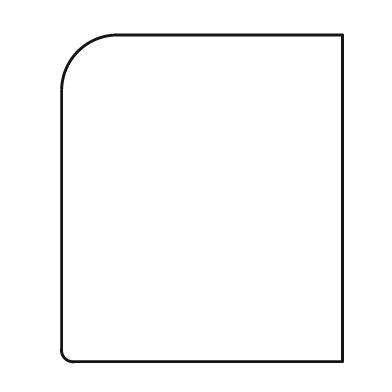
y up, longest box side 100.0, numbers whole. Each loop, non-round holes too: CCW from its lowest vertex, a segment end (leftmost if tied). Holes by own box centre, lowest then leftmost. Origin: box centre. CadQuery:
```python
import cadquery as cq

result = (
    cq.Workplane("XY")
    .moveTo(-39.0, -50.0)
    .lineTo(43.0, -50.0)
    .lineTo(43.0, 50.0)
    .lineTo(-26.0, 50.0)
    .threePointArc((-38.0, 45.0), (-43.0, 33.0))
    .lineTo(-43.0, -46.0)
    .threePointArc((-42.0, -49.0), (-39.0, -50.0))
    .close()
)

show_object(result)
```